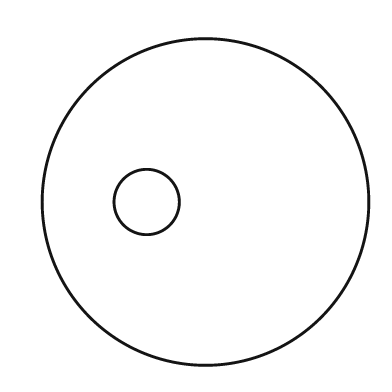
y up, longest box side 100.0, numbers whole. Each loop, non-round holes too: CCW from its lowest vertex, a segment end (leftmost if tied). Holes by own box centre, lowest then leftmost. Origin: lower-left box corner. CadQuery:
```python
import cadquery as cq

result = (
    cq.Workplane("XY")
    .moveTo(50.0, 50.0)
    .circle(50.0)
    .moveTo(32.0, 50.0)
    .circle(10.0)
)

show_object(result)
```